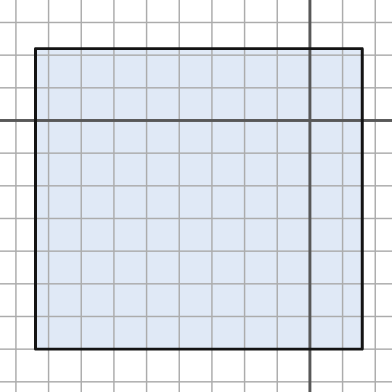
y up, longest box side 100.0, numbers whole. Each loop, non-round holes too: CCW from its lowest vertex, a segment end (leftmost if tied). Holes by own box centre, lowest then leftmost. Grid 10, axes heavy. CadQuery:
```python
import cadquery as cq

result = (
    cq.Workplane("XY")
    .moveTo(-84.0, -70.0)
    .lineTo(16.0, -70.0)
    .lineTo(16.0, 22.0)
    .lineTo(-84.0, 22.0)
    .close()
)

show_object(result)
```